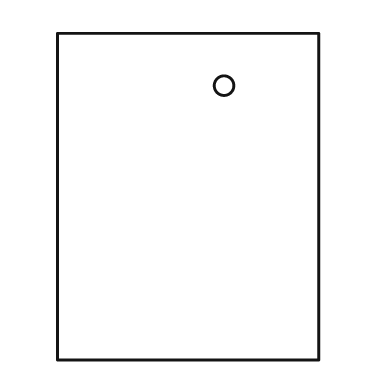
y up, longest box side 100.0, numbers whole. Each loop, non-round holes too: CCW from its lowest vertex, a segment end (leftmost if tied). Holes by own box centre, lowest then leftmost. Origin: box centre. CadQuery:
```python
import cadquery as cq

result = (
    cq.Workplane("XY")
    .moveTo(-40.0, -50.0)
    .lineTo(40.0, -50.0)
    .lineTo(40.0, 50.0)
    .lineTo(-40.0, 50.0)
    .close()
    .moveTo(11.0, 34.0)
    .circle(3.0)
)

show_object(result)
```